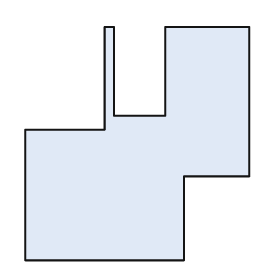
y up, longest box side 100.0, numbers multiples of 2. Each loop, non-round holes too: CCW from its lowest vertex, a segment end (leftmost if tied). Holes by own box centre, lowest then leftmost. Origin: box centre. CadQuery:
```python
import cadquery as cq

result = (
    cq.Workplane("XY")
    .moveTo(-48.0, -50.0)
    .lineTo(20.0, -50.0)
    .lineTo(20.0, -14.0)
    .lineTo(48.0, -14.0)
    .lineTo(48.0, 50.0)
    .lineTo(12.0, 50.0)
    .lineTo(12.0, 12.0)
    .lineTo(-10.0, 12.0)
    .lineTo(-10.0, 50.0)
    .lineTo(-14.0, 50.0)
    .lineTo(-14.0, 6.0)
    .lineTo(-48.0, 6.0)
    .close()
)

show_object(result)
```